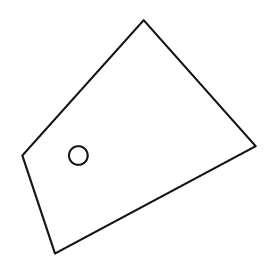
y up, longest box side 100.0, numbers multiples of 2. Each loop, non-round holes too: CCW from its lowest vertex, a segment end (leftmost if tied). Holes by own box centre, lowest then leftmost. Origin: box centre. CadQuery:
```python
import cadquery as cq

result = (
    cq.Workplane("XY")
    .moveTo(-36.0, -50.0)
    .lineTo(50.0, -4.0)
    .lineTo(2.0, 50.0)
    .lineTo(-50.0, -8.0)
    .close()
    .moveTo(-26.0, -8.0)
    .circle(4.0)
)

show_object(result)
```